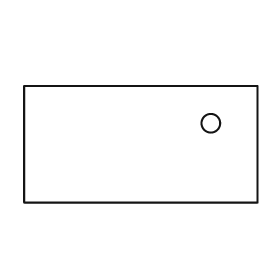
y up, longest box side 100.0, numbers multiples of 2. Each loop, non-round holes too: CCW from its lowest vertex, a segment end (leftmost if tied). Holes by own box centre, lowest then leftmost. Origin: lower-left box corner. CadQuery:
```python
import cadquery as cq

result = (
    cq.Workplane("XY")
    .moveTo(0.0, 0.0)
    .lineTo(100.0, 0.0)
    .lineTo(100.0, 50.0)
    .lineTo(0.0, 50.0)
    .close()
    .moveTo(80.0, 34.0)
    .circle(4.0)
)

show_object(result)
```